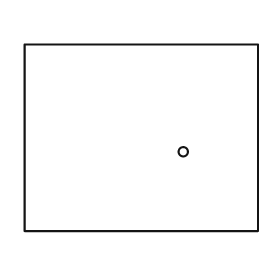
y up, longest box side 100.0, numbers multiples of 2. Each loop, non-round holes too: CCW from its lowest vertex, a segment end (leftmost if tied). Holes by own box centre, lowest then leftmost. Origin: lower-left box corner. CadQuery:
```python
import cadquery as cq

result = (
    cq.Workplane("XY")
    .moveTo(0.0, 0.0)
    .lineTo(100.0, 0.0)
    .lineTo(100.0, 80.0)
    .lineTo(0.0, 80.0)
    .close()
    .moveTo(68.0, 34.0)
    .circle(2.0)
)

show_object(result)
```